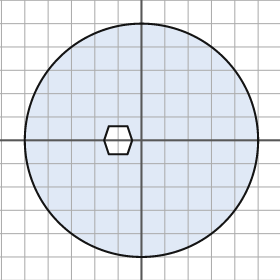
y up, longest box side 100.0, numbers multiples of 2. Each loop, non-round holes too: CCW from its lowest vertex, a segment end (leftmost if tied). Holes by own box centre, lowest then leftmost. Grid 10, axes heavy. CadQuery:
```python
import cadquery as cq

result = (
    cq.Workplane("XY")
    .moveTo(0.0, 0.0)
    .circle(50.0)
    .moveTo(-14.0, -6.0)
    .lineTo(-6.0, -6.0)
    .lineTo(-4.0, 0.0)
    .lineTo(-6.0, 6.0)
    .lineTo(-14.0, 6.0)
    .lineTo(-16.0, 0.0)
    .close()
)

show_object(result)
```